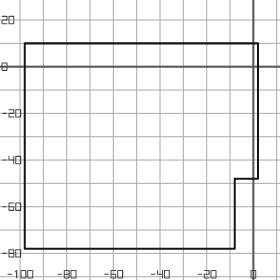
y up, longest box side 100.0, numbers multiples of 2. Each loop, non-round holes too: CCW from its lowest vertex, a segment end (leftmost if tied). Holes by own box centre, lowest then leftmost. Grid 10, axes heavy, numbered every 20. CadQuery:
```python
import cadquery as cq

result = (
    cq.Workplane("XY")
    .moveTo(-98.0, -78.0)
    .lineTo(-8.0, -78.0)
    .lineTo(-8.0, -48.0)
    .lineTo(2.0, -48.0)
    .lineTo(2.0, 10.0)
    .lineTo(-98.0, 10.0)
    .close()
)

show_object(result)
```